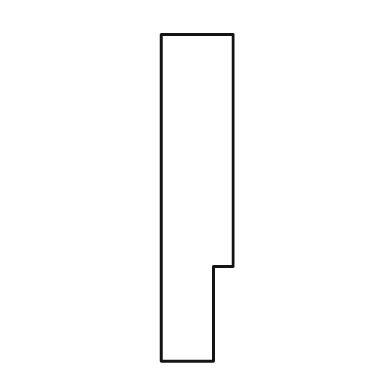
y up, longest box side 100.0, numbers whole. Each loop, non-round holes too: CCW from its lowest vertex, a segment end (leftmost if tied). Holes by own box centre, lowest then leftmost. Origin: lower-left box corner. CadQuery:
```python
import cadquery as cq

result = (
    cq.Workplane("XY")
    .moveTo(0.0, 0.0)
    .lineTo(16.0, 0.0)
    .lineTo(16.0, 29.0)
    .lineTo(22.0, 29.0)
    .lineTo(22.0, 100.0)
    .lineTo(0.0, 100.0)
    .close()
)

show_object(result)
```